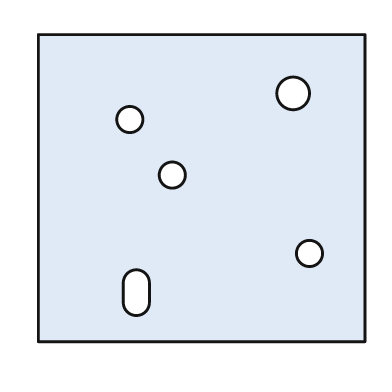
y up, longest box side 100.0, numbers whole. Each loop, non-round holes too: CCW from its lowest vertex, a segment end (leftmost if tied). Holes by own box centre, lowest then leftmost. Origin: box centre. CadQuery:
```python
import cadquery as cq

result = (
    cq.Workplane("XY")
    .moveTo(-50.0, -47.0)
    .lineTo(50.0, -47.0)
    .lineTo(50.0, 47.0)
    .lineTo(-50.0, 47.0)
    .close()
    .moveTo(-24.0, -35.0)
    .threePointArc((-20.0, -39.0), (-16.0, -35.0))
    .lineTo(-16.0, -29.0)
    .threePointArc((-20.0, -25.0), (-24.0, -29.0))
    .close()
    .moveTo(33.0, -20.0)
    .circle(4.0)
    .moveTo(-9.0, 4.0)
    .circle(4.0)
    .moveTo(-22.0, 21.0)
    .circle(4.0)
    .moveTo(28.0, 29.0)
    .circle(5.0)
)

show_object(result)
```